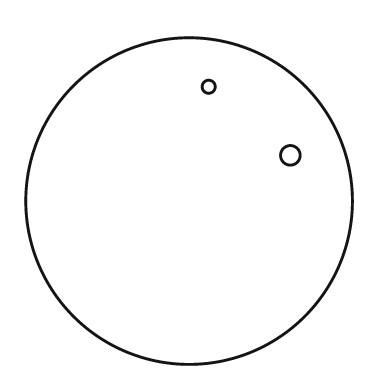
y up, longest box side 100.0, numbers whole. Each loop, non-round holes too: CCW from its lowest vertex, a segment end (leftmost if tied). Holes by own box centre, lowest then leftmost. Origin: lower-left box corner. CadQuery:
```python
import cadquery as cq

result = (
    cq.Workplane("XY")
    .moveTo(50.0, 50.0)
    .circle(50.0)
    .moveTo(81.0, 64.0)
    .circle(3.0)
    .moveTo(56.0, 85.0)
    .circle(2.0)
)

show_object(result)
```